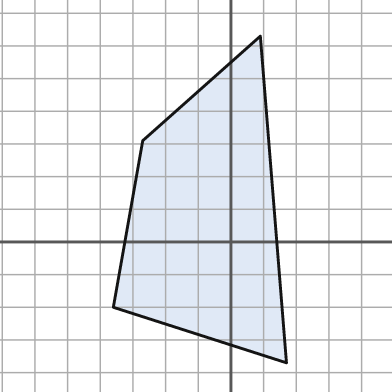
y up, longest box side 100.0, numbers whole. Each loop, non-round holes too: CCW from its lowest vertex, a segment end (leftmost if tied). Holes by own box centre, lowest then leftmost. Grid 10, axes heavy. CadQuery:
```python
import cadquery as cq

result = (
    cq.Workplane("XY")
    .moveTo(17.0, -37.0)
    .lineTo(9.0, 63.0)
    .lineTo(-27.0, 31.0)
    .lineTo(-36.0, -20.0)
    .close()
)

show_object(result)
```